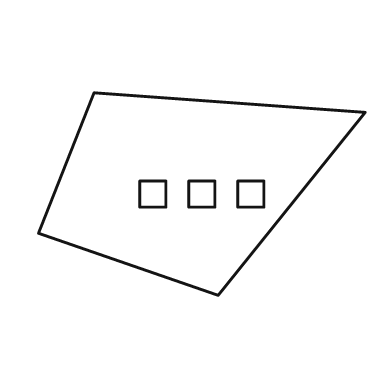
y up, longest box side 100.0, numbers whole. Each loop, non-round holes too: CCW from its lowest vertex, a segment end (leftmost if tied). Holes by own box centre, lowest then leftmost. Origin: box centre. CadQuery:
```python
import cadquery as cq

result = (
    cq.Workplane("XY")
    .moveTo(5.0, -31.0)
    .lineTo(50.0, 25.0)
    .lineTo(-33.0, 31.0)
    .lineTo(-50.0, -12.0)
    .close()
    .moveTo(-19.0, -4.0)
    .lineTo(-11.0, -4.0)
    .lineTo(-11.0, 4.0)
    .lineTo(-19.0, 4.0)
    .close()
    .moveTo(-4.0, -4.0)
    .lineTo(4.0, -4.0)
    .lineTo(4.0, 4.0)
    .lineTo(-4.0, 4.0)
    .close()
    .moveTo(11.0, -4.0)
    .lineTo(19.0, -4.0)
    .lineTo(19.0, 4.0)
    .lineTo(11.0, 4.0)
    .close()
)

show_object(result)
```